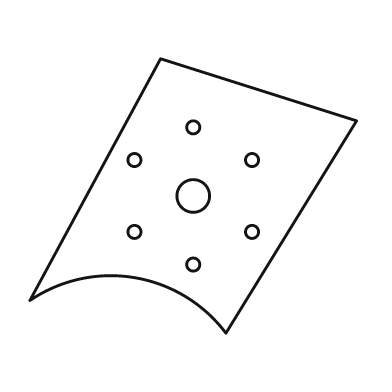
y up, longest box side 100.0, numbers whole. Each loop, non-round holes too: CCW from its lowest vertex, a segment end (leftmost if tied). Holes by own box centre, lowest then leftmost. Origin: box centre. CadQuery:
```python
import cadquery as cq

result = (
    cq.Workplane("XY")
    .moveTo(10.0, -42.0)
    .lineTo(50.0, 23.0)
    .lineTo(-10.0, 42.0)
    .lineTo(-50.0, -32.0)
    .threePointArc((-18.0, -25.0), (10.0, -42.0))
    .close()
    .moveTo(0.0, -21.0)
    .circle(2.0)
    .moveTo(-18.0, -11.0)
    .circle(2.0)
    .moveTo(18.0, -11.0)
    .circle(2.0)
    .moveTo(0.0, 0.0)
    .circle(5.0)
    .moveTo(-18.0, 11.0)
    .circle(2.0)
    .moveTo(18.0, 11.0)
    .circle(2.0)
    .moveTo(0.0, 21.0)
    .circle(2.0)
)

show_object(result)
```